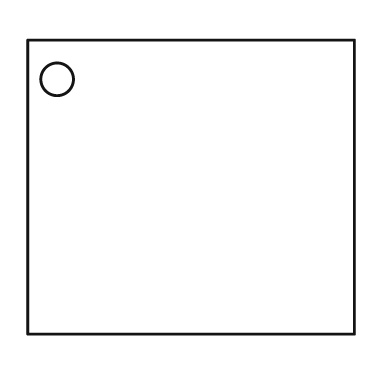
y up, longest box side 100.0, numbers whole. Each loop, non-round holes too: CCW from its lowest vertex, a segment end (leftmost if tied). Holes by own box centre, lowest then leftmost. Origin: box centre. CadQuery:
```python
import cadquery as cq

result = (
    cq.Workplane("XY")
    .moveTo(-50.0, -45.0)
    .lineTo(50.0, -45.0)
    .lineTo(50.0, 45.0)
    .lineTo(-50.0, 45.0)
    .close()
    .moveTo(-41.0, 33.0)
    .circle(5.0)
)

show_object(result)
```